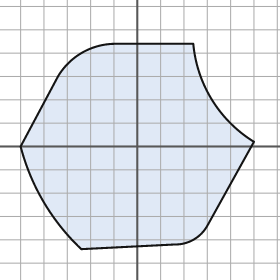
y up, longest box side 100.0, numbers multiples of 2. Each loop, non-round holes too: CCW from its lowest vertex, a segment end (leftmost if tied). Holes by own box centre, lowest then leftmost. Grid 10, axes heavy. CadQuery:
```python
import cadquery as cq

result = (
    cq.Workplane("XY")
    .moveTo(-24.0, -44.0)
    .lineTo(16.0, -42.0)
    .threePointArc((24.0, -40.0), (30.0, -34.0))
    .lineTo(50.0, 2.0)
    .threePointArc((32.0, 20.0), (24.0, 44.0))
    .lineTo(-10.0, 44.0)
    .threePointArc((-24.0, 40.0), (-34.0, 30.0))
    .lineTo(-50.0, 0.0)
    .threePointArc((-40.0, -24.0), (-24.0, -44.0))
    .close()
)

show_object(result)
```